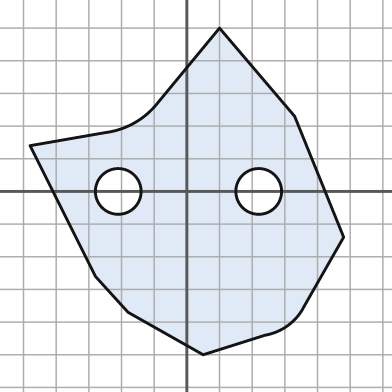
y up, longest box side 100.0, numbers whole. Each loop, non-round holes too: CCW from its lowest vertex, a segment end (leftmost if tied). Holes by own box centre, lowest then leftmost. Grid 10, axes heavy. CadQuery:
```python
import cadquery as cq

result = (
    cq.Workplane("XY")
    .moveTo(5.0, -50.0)
    .lineTo(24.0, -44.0)
    .threePointArc((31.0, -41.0), (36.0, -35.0))
    .lineTo(48.0, -14.0)
    .lineTo(33.0, 23.0)
    .lineTo(10.0, 50.0)
    .lineTo(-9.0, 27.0)
    .threePointArc((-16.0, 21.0), (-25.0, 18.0))
    .lineTo(-48.0, 14.0)
    .lineTo(-28.0, -26.0)
    .lineTo(-18.0, -37.0)
    .close()
    .moveTo(-21.0, 0.0)
    .circle(7.0)
    .moveTo(22.0, 0.0)
    .circle(7.0)
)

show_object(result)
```